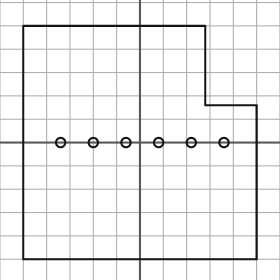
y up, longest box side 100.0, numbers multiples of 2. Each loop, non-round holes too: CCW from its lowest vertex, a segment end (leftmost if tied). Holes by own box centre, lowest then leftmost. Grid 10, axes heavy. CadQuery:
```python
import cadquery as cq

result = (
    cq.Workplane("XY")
    .moveTo(-50.0, -50.0)
    .lineTo(50.0, -50.0)
    .lineTo(50.0, 16.0)
    .lineTo(28.0, 16.0)
    .lineTo(28.0, 50.0)
    .lineTo(-50.0, 50.0)
    .close()
    .moveTo(-34.0, 0.0)
    .circle(2.0)
    .moveTo(-20.0, 0.0)
    .circle(2.0)
    .moveTo(-6.0, 0.0)
    .circle(2.0)
    .moveTo(8.0, 0.0)
    .circle(2.0)
    .moveTo(22.0, 0.0)
    .circle(2.0)
    .moveTo(36.0, 0.0)
    .circle(2.0)
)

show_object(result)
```